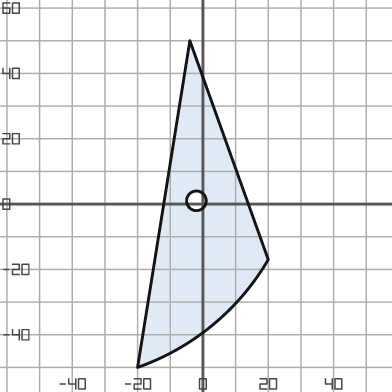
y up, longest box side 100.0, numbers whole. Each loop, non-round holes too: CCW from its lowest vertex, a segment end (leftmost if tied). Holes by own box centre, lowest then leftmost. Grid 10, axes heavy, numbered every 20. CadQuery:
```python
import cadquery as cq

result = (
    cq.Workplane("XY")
    .moveTo(-20.0, -50.0)
    .threePointArc((3.0, -37.0), (20.0, -17.0))
    .lineTo(-4.0, 50.0)
    .close()
    .moveTo(-2.0, 1.0)
    .circle(3.0)
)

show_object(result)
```